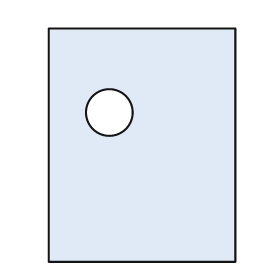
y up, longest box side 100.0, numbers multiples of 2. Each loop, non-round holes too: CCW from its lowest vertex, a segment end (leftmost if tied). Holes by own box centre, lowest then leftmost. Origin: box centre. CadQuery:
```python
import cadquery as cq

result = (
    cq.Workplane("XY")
    .moveTo(-40.0, -50.0)
    .lineTo(40.0, -50.0)
    .lineTo(40.0, 50.0)
    .lineTo(-40.0, 50.0)
    .close()
    .moveTo(-14.0, 14.0)
    .circle(10.0)
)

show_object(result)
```